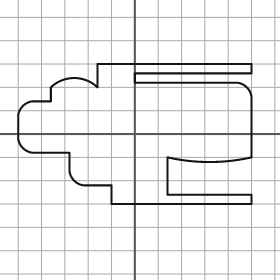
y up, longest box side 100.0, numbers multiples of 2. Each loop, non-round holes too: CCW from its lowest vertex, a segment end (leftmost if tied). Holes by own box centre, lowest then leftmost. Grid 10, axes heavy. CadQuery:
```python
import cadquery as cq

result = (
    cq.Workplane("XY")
    .moveTo(-10.0, -30.0)
    .lineTo(50.0, -30.0)
    .lineTo(50.0, -26.0)
    .lineTo(14.0, -26.0)
    .lineTo(14.0, -10.0)
    .threePointArc((32.0, -12.0), (50.0, -10.0))
    .lineTo(50.0, 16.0)
    .threePointArc((48.0, 20.0), (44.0, 22.0))
    .lineTo(0.0, 22.0)
    .lineTo(0.0, 26.0)
    .lineTo(50.0, 26.0)
    .lineTo(50.0, 30.0)
    .lineTo(-16.0, 30.0)
    .lineTo(-16.0, 20.0)
    .threePointArc((-26.0, 24.0), (-36.0, 20.0))
    .lineTo(-36.0, 14.0)
    .lineTo(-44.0, 14.0)
    .threePointArc((-48.0, 12.0), (-50.0, 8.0))
    .lineTo(-50.0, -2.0)
    .threePointArc((-48.0, -6.0), (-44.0, -8.0))
    .lineTo(-28.0, -8.0)
    .lineTo(-28.0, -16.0)
    .threePointArc((-26.0, -20.0), (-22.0, -22.0))
    .lineTo(-10.0, -22.0)
    .close()
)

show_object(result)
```